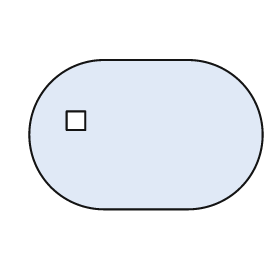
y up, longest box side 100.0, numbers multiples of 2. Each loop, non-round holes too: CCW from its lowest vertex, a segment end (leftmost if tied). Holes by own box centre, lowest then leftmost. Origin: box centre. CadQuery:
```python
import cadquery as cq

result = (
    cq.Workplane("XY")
    .moveTo(-18.0, -32.0)
    .lineTo(18.0, -32.0)
    .threePointArc((50.0, 0.0), (18.0, 32.0))
    .lineTo(-18.0, 32.0)
    .threePointArc((-50.0, 0.0), (-18.0, -32.0))
    .close()
    .moveTo(-34.0, 2.0)
    .lineTo(-26.0, 2.0)
    .lineTo(-26.0, 10.0)
    .lineTo(-34.0, 10.0)
    .close()
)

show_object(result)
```